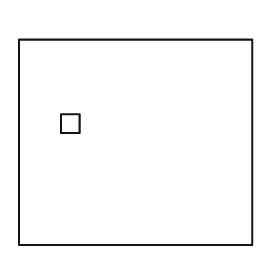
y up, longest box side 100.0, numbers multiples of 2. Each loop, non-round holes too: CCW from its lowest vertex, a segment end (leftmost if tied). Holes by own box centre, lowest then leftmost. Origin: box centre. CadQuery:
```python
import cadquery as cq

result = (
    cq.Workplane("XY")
    .moveTo(-50.0, -44.0)
    .lineTo(50.0, -44.0)
    .lineTo(50.0, 44.0)
    .lineTo(-50.0, 44.0)
    .close()
    .moveTo(-32.0, 4.0)
    .lineTo(-24.0, 4.0)
    .lineTo(-24.0, 12.0)
    .lineTo(-32.0, 12.0)
    .close()
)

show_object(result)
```